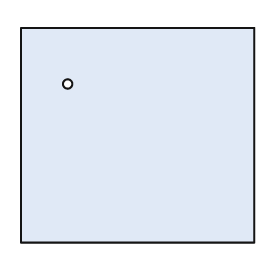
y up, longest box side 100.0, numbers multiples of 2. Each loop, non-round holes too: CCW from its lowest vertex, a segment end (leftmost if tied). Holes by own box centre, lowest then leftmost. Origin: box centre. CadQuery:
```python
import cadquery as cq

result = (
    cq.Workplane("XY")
    .moveTo(-50.0, -46.0)
    .lineTo(50.0, -46.0)
    .lineTo(50.0, 46.0)
    .lineTo(-50.0, 46.0)
    .close()
    .moveTo(-30.0, 22.0)
    .circle(2.0)
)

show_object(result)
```